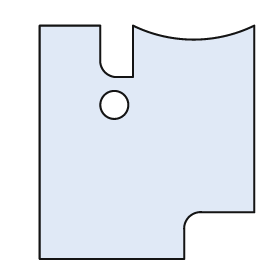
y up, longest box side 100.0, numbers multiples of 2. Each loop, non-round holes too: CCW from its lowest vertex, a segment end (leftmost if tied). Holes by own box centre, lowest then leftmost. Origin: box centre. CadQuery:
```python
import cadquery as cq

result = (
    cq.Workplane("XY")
    .moveTo(-46.0, -50.0)
    .lineTo(16.0, -50.0)
    .lineTo(16.0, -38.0)
    .threePointArc((18.0, -32.0), (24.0, -30.0))
    .lineTo(46.0, -30.0)
    .lineTo(46.0, 50.0)
    .threePointArc((20.0, 44.0), (-6.0, 50.0))
    .lineTo(-6.0, 28.0)
    .lineTo(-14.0, 28.0)
    .threePointArc((-18.0, 30.0), (-20.0, 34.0))
    .lineTo(-20.0, 50.0)
    .lineTo(-46.0, 50.0)
    .close()
    .moveTo(-14.0, 16.0)
    .circle(6.0)
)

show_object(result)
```